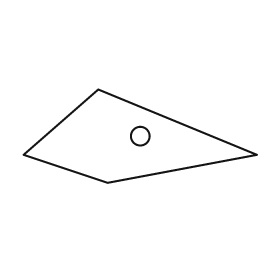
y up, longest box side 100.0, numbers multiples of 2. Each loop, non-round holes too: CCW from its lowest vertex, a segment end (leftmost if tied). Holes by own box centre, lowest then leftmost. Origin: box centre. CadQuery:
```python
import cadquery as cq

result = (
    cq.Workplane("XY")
    .moveTo(-14.0, -20.0)
    .lineTo(50.0, -8.0)
    .lineTo(-18.0, 20.0)
    .lineTo(-50.0, -8.0)
    .close()
    .moveTo(0.0, 0.0)
    .circle(4.0)
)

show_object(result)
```